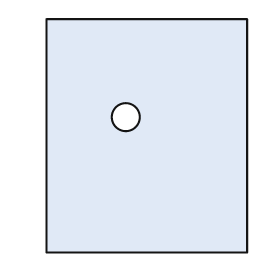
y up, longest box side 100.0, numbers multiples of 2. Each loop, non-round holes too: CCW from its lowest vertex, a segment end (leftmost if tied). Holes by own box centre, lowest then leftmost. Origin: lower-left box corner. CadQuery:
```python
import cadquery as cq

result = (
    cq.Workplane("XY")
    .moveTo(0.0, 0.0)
    .lineTo(86.0, 0.0)
    .lineTo(86.0, 100.0)
    .lineTo(0.0, 100.0)
    .close()
    .moveTo(34.0, 58.0)
    .circle(6.0)
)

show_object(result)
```